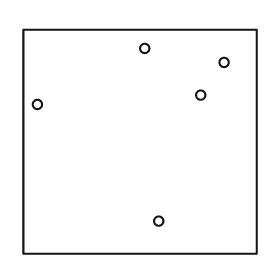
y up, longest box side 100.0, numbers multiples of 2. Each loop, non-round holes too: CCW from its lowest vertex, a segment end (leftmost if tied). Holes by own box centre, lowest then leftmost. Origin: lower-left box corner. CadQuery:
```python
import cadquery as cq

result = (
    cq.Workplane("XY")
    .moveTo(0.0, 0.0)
    .lineTo(100.0, 0.0)
    .lineTo(100.0, 96.0)
    .lineTo(0.0, 96.0)
    .close()
    .moveTo(58.0, 14.0)
    .circle(2.0)
    .moveTo(6.0, 64.0)
    .circle(2.0)
    .moveTo(76.0, 68.0)
    .circle(2.0)
    .moveTo(86.0, 82.0)
    .circle(2.0)
    .moveTo(52.0, 88.0)
    .circle(2.0)
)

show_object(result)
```